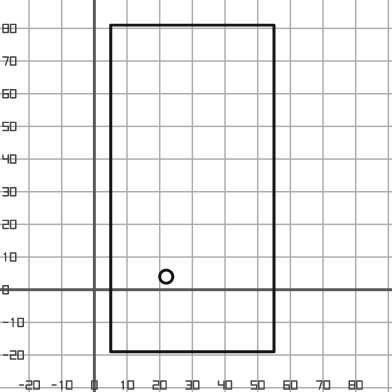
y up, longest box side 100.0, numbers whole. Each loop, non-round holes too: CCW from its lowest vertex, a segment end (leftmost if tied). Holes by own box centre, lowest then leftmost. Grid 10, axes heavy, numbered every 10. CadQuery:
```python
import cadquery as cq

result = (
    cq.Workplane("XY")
    .moveTo(5.0, -19.0)
    .lineTo(55.0, -19.0)
    .lineTo(55.0, 81.0)
    .lineTo(5.0, 81.0)
    .close()
    .moveTo(22.0, 4.0)
    .circle(2.0)
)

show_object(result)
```